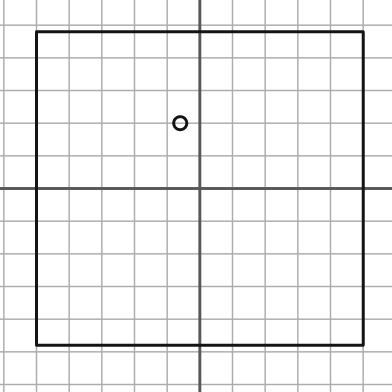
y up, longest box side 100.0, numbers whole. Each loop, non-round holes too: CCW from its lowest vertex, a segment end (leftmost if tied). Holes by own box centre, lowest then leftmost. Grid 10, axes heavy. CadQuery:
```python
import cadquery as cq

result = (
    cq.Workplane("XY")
    .moveTo(-50.0, -48.0)
    .lineTo(50.0, -48.0)
    .lineTo(50.0, 48.0)
    .lineTo(-50.0, 48.0)
    .close()
    .moveTo(-6.0, 20.0)
    .circle(2.0)
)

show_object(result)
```